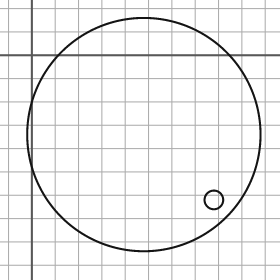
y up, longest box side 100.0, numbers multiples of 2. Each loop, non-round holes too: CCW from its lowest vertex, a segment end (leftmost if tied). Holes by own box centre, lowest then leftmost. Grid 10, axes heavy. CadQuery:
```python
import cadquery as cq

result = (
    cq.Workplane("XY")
    .moveTo(48.0, -34.0)
    .circle(50.0)
    .moveTo(78.0, -62.0)
    .circle(4.0)
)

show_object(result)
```